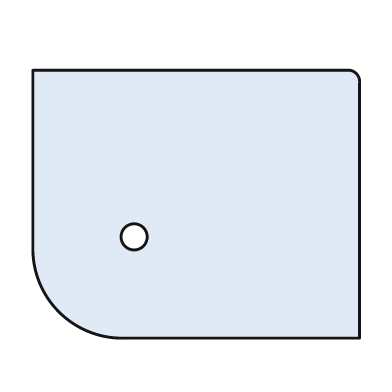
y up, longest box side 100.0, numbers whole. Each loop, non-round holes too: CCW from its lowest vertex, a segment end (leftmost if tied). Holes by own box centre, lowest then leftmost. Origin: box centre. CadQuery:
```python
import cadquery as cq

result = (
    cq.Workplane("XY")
    .moveTo(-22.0, -41.0)
    .lineTo(50.0, -41.0)
    .lineTo(50.0, 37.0)
    .threePointArc((49.0, 40.0), (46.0, 41.0))
    .lineTo(-50.0, 41.0)
    .lineTo(-50.0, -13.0)
    .threePointArc((-42.0, -33.0), (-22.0, -41.0))
    .close()
    .moveTo(-19.0, -10.0)
    .circle(4.0)
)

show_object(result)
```